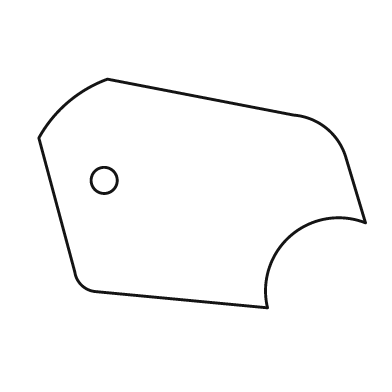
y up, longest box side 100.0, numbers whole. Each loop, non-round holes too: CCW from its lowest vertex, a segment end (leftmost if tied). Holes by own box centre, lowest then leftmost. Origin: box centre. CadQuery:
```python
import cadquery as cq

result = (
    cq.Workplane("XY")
    .moveTo(20.0, -35.0)
    .threePointArc((27.0, -13.0), (50.0, -9.0))
    .lineTo(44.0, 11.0)
    .threePointArc((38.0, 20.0), (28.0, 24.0))
    .lineTo(-29.0, 35.0)
    .threePointArc((-41.0, 28.0), (-50.0, 17.0))
    .lineTo(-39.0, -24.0)
    .threePointArc((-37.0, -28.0), (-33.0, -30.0))
    .close()
    .moveTo(-30.0, 4.0)
    .circle(4.0)
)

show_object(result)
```